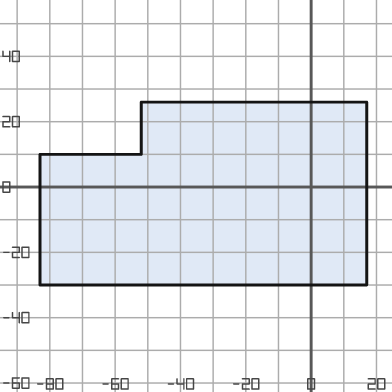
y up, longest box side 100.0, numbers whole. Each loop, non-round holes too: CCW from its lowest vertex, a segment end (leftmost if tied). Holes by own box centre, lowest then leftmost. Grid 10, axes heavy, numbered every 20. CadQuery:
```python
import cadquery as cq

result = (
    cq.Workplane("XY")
    .moveTo(-83.0, -30.0)
    .lineTo(17.0, -30.0)
    .lineTo(17.0, 26.0)
    .lineTo(-52.0, 26.0)
    .lineTo(-52.0, 10.0)
    .lineTo(-83.0, 10.0)
    .close()
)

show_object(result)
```